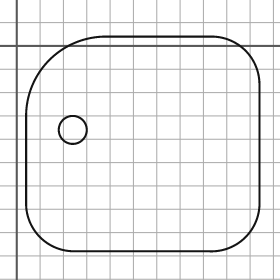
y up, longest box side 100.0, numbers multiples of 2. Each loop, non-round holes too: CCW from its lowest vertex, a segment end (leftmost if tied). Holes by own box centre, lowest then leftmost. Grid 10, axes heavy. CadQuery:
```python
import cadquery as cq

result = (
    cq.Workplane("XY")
    .moveTo(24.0, -88.0)
    .lineTo(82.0, -88.0)
    .threePointArc((98.0, -82.0), (104.0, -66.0))
    .lineTo(104.0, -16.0)
    .threePointArc((98.0, -2.0), (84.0, 4.0))
    .lineTo(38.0, 4.0)
    .threePointArc((14.0, -6.0), (4.0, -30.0))
    .lineTo(4.0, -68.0)
    .threePointArc((10.0, -82.0), (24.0, -88.0))
    .close()
    .moveTo(24.0, -36.0)
    .circle(6.0)
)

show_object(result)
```